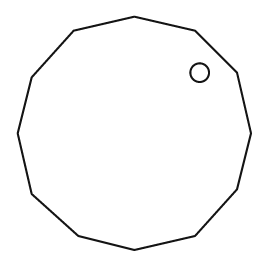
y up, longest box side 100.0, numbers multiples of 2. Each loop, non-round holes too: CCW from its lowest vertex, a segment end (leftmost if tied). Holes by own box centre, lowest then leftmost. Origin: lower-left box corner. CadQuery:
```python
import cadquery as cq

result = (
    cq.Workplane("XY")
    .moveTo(50.0, 0.0)
    .lineTo(76.0, 6.0)
    .lineTo(94.0, 26.0)
    .lineTo(100.0, 50.0)
    .lineTo(94.0, 76.0)
    .lineTo(76.0, 94.0)
    .lineTo(50.0, 100.0)
    .lineTo(24.0, 94.0)
    .lineTo(6.0, 74.0)
    .lineTo(0.0, 50.0)
    .lineTo(6.0, 24.0)
    .lineTo(26.0, 6.0)
    .close()
    .moveTo(78.0, 76.0)
    .circle(4.0)
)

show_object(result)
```